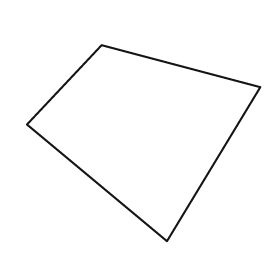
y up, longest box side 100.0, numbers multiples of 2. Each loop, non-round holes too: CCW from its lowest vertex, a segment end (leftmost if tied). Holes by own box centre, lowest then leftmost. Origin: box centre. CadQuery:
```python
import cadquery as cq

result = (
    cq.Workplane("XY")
    .moveTo(10.0, -42.0)
    .lineTo(50.0, 24.0)
    .lineTo(-18.0, 42.0)
    .lineTo(-50.0, 8.0)
    .close()
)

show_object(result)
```